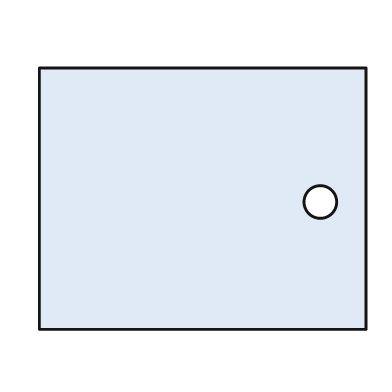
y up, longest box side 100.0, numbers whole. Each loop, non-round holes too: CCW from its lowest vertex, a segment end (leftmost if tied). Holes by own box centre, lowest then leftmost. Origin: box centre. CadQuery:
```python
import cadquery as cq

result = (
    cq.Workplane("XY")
    .moveTo(-50.0, -40.0)
    .lineTo(50.0, -40.0)
    .lineTo(50.0, 40.0)
    .lineTo(-50.0, 40.0)
    .close()
    .moveTo(36.0, -1.0)
    .circle(5.0)
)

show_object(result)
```